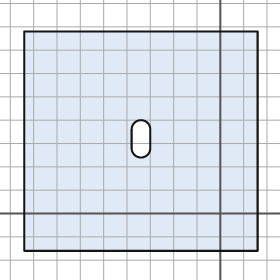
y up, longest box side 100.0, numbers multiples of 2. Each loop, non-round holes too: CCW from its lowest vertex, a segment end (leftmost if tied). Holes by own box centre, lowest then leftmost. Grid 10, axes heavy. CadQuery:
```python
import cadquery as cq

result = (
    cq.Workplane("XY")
    .moveTo(-84.0, -16.0)
    .lineTo(16.0, -16.0)
    .lineTo(16.0, 78.0)
    .lineTo(-84.0, 78.0)
    .close()
    .moveTo(-38.0, 28.0)
    .threePointArc((-34.0, 24.0), (-30.0, 28.0))
    .lineTo(-30.0, 36.0)
    .threePointArc((-34.0, 40.0), (-38.0, 36.0))
    .close()
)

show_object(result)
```